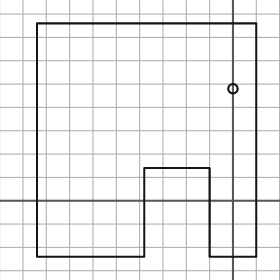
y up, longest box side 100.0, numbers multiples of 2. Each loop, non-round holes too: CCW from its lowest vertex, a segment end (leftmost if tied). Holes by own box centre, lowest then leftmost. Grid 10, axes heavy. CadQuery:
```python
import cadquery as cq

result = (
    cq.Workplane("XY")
    .moveTo(-84.0, -24.0)
    .lineTo(-38.0, -24.0)
    .lineTo(-38.0, 14.0)
    .lineTo(-10.0, 14.0)
    .lineTo(-10.0, -24.0)
    .lineTo(10.0, -24.0)
    .lineTo(10.0, 76.0)
    .lineTo(-84.0, 76.0)
    .close()
    .moveTo(0.0, 48.0)
    .circle(2.0)
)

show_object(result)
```